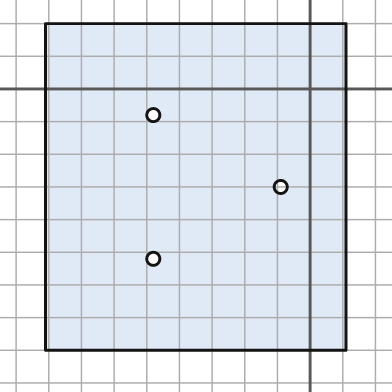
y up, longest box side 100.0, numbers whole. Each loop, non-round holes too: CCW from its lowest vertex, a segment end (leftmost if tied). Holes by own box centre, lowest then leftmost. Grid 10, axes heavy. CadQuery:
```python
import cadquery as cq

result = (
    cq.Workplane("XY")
    .moveTo(-81.0, -80.0)
    .lineTo(11.0, -80.0)
    .lineTo(11.0, 20.0)
    .lineTo(-81.0, 20.0)
    .close()
    .moveTo(-48.0, -52.0)
    .circle(2.0)
    .moveTo(-9.0, -30.0)
    .circle(2.0)
    .moveTo(-48.0, -8.0)
    .circle(2.0)
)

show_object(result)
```